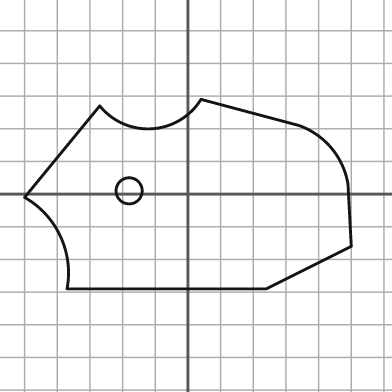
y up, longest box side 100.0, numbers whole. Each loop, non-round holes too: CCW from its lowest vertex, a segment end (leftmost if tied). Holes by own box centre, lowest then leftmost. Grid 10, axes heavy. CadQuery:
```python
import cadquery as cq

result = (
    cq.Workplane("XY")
    .moveTo(-37.0, -29.0)
    .lineTo(24.0, -29.0)
    .lineTo(50.0, -16.0)
    .lineTo(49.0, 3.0)
    .threePointArc((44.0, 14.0), (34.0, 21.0))
    .lineTo(4.0, 29.0)
    .threePointArc((-11.0, 20.0), (-27.0, 27.0))
    .lineTo(-50.0, -1.0)
    .threePointArc((-39.0, -13.0), (-37.0, -29.0))
    .close()
    .moveTo(-18.0, 1.0)
    .circle(4.0)
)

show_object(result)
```